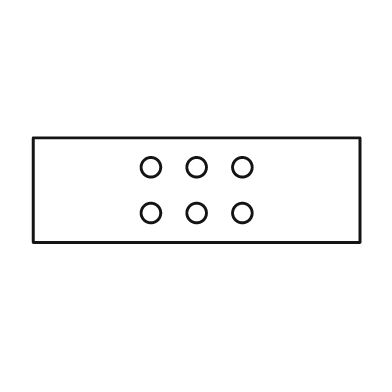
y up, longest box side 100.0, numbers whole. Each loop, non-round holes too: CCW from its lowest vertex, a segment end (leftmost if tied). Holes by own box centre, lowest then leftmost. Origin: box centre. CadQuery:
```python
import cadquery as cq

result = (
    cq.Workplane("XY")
    .moveTo(-50.0, -16.0)
    .lineTo(50.0, -16.0)
    .lineTo(50.0, 16.0)
    .lineTo(-50.0, 16.0)
    .close()
    .moveTo(-14.0, -7.0)
    .circle(3.0)
    .moveTo(0.0, -7.0)
    .circle(3.0)
    .moveTo(14.0, -7.0)
    .circle(3.0)
    .moveTo(-14.0, 7.0)
    .circle(3.0)
    .moveTo(0.0, 7.0)
    .circle(3.0)
    .moveTo(14.0, 7.0)
    .circle(3.0)
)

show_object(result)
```